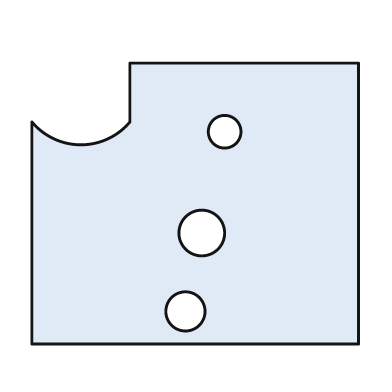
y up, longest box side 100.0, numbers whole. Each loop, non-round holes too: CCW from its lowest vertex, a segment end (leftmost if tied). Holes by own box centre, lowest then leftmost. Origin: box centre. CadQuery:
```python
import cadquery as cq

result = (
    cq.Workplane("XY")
    .moveTo(-50.0, -43.0)
    .lineTo(50.0, -43.0)
    .lineTo(50.0, 43.0)
    .lineTo(-20.0, 43.0)
    .lineTo(-20.0, 25.0)
    .threePointArc((-35.0, 18.0), (-50.0, 25.0))
    .close()
    .moveTo(-3.0, -33.0)
    .circle(6.0)
    .moveTo(2.0, -9.0)
    .circle(7.0)
    .moveTo(9.0, 22.0)
    .circle(5.0)
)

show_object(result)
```